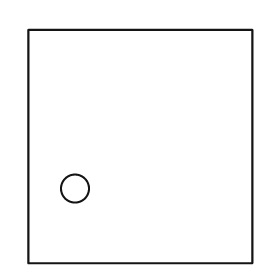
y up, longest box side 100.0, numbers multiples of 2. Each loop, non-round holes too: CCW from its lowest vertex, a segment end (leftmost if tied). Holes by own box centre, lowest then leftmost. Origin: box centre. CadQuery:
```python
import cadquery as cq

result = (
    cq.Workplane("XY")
    .moveTo(-48.0, -50.0)
    .lineTo(48.0, -50.0)
    .lineTo(48.0, 50.0)
    .lineTo(-48.0, 50.0)
    .close()
    .moveTo(-28.0, -18.0)
    .circle(6.0)
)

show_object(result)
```